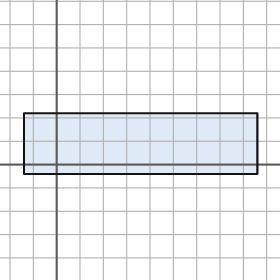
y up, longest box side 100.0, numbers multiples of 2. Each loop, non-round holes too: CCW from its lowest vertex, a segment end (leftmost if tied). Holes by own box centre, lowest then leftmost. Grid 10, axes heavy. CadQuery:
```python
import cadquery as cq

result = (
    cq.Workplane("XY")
    .moveTo(-14.0, -4.0)
    .lineTo(86.0, -4.0)
    .lineTo(86.0, 22.0)
    .lineTo(-14.0, 22.0)
    .close()
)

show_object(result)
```